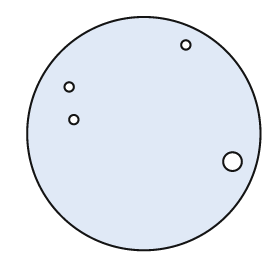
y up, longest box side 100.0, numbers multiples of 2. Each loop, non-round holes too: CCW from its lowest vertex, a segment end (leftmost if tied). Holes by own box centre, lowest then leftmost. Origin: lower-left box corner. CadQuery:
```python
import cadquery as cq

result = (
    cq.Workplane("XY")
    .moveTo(50.0, 50.0)
    .circle(50.0)
    .moveTo(88.0, 38.0)
    .circle(4.0)
    .moveTo(20.0, 56.0)
    .circle(2.0)
    .moveTo(18.0, 70.0)
    .circle(2.0)
    .moveTo(68.0, 88.0)
    .circle(2.0)
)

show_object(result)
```